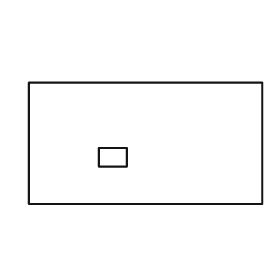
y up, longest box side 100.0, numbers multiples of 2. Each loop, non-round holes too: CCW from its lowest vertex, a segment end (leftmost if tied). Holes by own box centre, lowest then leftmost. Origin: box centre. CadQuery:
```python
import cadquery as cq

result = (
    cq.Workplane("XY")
    .moveTo(-50.0, -26.0)
    .lineTo(50.0, -26.0)
    .lineTo(50.0, 26.0)
    .lineTo(-50.0, 26.0)
    .close()
    .moveTo(-20.0, -10.0)
    .lineTo(-8.0, -10.0)
    .lineTo(-8.0, -2.0)
    .lineTo(-20.0, -2.0)
    .close()
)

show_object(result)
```